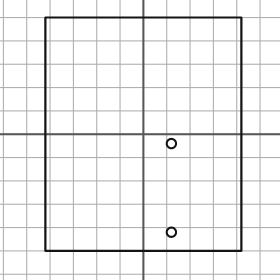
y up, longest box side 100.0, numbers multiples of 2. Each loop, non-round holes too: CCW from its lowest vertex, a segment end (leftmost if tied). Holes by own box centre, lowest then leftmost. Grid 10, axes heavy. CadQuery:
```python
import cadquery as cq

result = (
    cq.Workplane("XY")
    .moveTo(-42.0, -50.0)
    .lineTo(42.0, -50.0)
    .lineTo(42.0, 50.0)
    .lineTo(-42.0, 50.0)
    .close()
    .moveTo(12.0, -42.0)
    .circle(2.0)
    .moveTo(12.0, -4.0)
    .circle(2.0)
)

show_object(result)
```